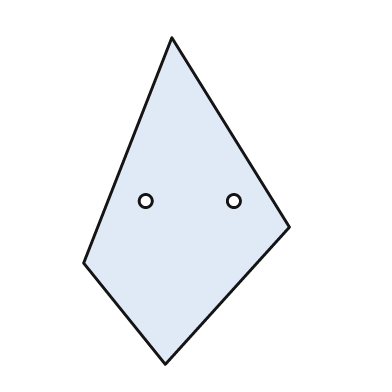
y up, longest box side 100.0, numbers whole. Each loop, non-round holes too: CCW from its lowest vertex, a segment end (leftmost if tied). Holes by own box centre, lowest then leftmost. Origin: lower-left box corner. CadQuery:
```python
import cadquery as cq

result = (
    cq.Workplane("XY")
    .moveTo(25.0, 0.0)
    .lineTo(63.0, 42.0)
    .lineTo(27.0, 100.0)
    .lineTo(0.0, 31.0)
    .close()
    .moveTo(19.0, 50.0)
    .circle(2.0)
    .moveTo(46.0, 50.0)
    .circle(2.0)
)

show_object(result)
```